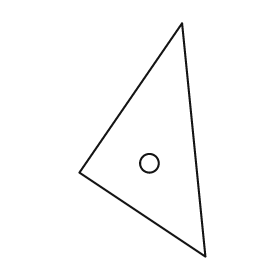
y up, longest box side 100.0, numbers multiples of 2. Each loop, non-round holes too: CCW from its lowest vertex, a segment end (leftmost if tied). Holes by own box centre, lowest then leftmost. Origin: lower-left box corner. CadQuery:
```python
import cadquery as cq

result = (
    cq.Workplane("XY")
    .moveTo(54.0, 0.0)
    .lineTo(44.0, 100.0)
    .lineTo(0.0, 36.0)
    .close()
    .moveTo(30.0, 40.0)
    .circle(4.0)
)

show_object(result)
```